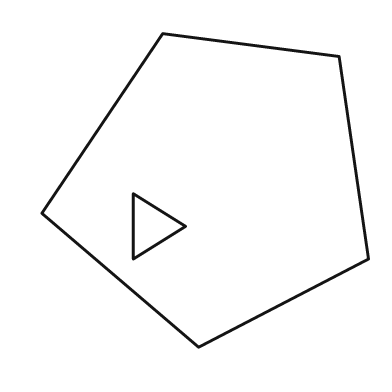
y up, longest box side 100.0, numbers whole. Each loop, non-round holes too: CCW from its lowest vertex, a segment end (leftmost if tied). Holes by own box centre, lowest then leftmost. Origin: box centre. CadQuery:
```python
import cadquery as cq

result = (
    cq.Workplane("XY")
    .moveTo(-2.0, -48.0)
    .lineTo(50.0, -21.0)
    .lineTo(41.0, 41.0)
    .lineTo(-13.0, 48.0)
    .lineTo(-50.0, -7.0)
    .close()
    .moveTo(-22.0, -21.0)
    .lineTo(-6.0, -11.0)
    .lineTo(-22.0, -1.0)
    .close()
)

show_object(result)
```